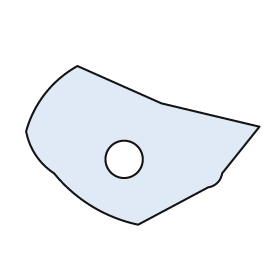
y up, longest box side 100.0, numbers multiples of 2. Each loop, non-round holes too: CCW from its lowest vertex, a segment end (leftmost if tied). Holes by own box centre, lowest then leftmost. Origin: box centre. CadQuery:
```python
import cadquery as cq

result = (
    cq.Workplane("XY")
    .moveTo(-2.0, -34.0)
    .lineTo(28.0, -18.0)
    .threePointArc((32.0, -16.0), (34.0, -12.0))
    .lineTo(50.0, 8.0)
    .lineTo(8.0, 18.0)
    .lineTo(-28.0, 34.0)
    .threePointArc((-42.0, 22.0), (-50.0, 6.0))
    .threePointArc((-46.0, -4.0), (-38.0, -12.0))
    .threePointArc((-22.0, -26.0), (-2.0, -34.0))
    .close()
    .moveTo(-8.0, -6.0)
    .circle(8.0)
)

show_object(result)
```